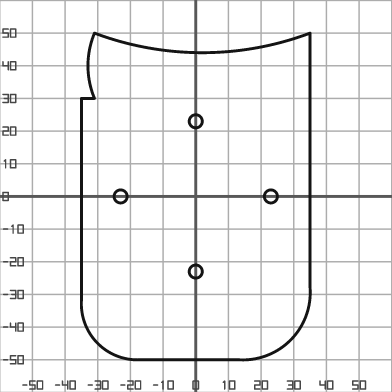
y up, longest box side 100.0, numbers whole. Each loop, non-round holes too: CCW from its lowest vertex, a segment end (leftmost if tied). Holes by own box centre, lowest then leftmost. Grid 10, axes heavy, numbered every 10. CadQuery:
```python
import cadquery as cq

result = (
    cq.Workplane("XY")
    .moveTo(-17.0, -50.0)
    .lineTo(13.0, -50.0)
    .threePointArc((29.0, -44.0), (35.0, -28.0))
    .lineTo(35.0, 50.0)
    .threePointArc((2.0, 44.0), (-31.0, 50.0))
    .threePointArc((-33.0, 40.0), (-31.0, 30.0))
    .lineTo(-35.0, 30.0)
    .lineTo(-35.0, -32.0)
    .threePointArc((-30.0, -45.0), (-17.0, -50.0))
    .close()
    .moveTo(0.0, -23.0)
    .circle(2.0)
    .moveTo(-23.0, 0.0)
    .circle(2.0)
    .moveTo(23.0, 0.0)
    .circle(2.0)
    .moveTo(0.0, 23.0)
    .circle(2.0)
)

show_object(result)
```